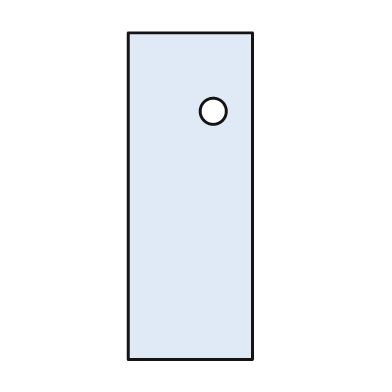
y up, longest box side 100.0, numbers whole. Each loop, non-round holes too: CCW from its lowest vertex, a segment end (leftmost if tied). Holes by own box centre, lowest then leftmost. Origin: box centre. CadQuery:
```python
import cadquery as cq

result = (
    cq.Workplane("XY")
    .moveTo(-19.0, -50.0)
    .lineTo(19.0, -50.0)
    .lineTo(19.0, 50.0)
    .lineTo(-19.0, 50.0)
    .close()
    .moveTo(7.0, 26.0)
    .circle(4.0)
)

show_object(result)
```